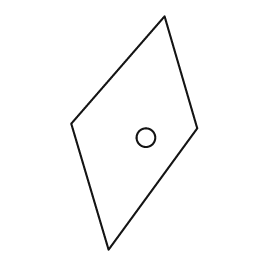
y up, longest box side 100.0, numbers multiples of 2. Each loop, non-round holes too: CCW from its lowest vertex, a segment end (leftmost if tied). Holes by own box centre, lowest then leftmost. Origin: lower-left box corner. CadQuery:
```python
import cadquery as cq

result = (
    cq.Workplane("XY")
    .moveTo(16.0, 0.0)
    .lineTo(54.0, 52.0)
    .lineTo(40.0, 100.0)
    .lineTo(0.0, 54.0)
    .close()
    .moveTo(32.0, 48.0)
    .circle(4.0)
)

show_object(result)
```